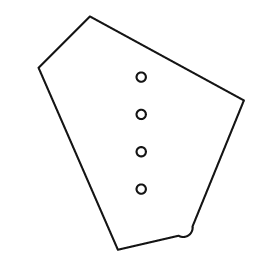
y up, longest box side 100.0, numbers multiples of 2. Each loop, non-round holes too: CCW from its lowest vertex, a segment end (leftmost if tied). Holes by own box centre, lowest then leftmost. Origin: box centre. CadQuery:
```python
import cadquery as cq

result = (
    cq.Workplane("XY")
    .moveTo(-10.0, -50.0)
    .lineTo(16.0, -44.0)
    .threePointArc((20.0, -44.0), (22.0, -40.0))
    .lineTo(44.0, 14.0)
    .lineTo(-22.0, 50.0)
    .lineTo(-44.0, 28.0)
    .close()
    .moveTo(0.0, -24.0)
    .circle(2.0)
    .moveTo(0.0, -8.0)
    .circle(2.0)
    .moveTo(0.0, 8.0)
    .circle(2.0)
    .moveTo(0.0, 24.0)
    .circle(2.0)
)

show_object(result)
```